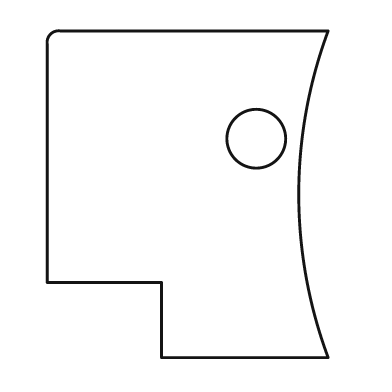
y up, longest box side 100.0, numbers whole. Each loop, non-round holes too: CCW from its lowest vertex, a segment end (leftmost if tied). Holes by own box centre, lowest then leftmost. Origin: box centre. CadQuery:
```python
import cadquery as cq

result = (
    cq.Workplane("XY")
    .moveTo(-8.0, -50.0)
    .lineTo(43.0, -50.0)
    .threePointArc((34.0, 0.0), (43.0, 50.0))
    .lineTo(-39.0, 50.0)
    .threePointArc((-42.0, 49.0), (-43.0, 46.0))
    .lineTo(-43.0, -27.0)
    .lineTo(-8.0, -27.0)
    .close()
    .moveTo(21.0, 17.0)
    .circle(9.0)
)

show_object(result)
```